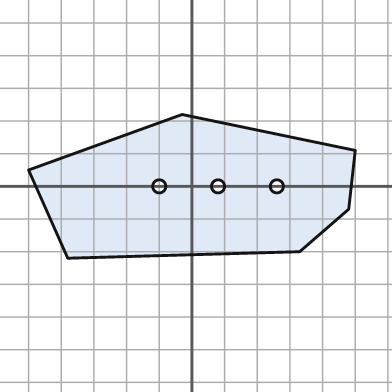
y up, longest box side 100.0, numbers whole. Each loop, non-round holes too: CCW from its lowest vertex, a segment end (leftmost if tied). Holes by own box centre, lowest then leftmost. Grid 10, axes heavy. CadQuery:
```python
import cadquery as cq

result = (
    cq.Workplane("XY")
    .moveTo(-38.0, -22.0)
    .lineTo(33.0, -20.0)
    .lineTo(48.0, -7.0)
    .lineTo(50.0, 11.0)
    .lineTo(-3.0, 22.0)
    .lineTo(-50.0, 5.0)
    .close()
    .moveTo(-10.0, 0.0)
    .circle(2.0)
    .moveTo(8.0, 0.0)
    .circle(2.0)
    .moveTo(26.0, 0.0)
    .circle(2.0)
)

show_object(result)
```